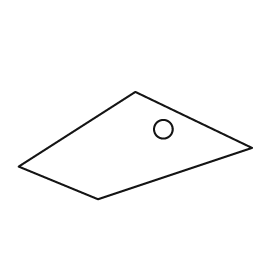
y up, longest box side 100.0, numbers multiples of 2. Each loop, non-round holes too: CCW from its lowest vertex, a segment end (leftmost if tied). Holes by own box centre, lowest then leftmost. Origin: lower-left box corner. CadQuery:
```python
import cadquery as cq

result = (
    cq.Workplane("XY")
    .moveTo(34.0, 0.0)
    .lineTo(100.0, 22.0)
    .lineTo(50.0, 46.0)
    .lineTo(0.0, 14.0)
    .close()
    .moveTo(62.0, 30.0)
    .circle(4.0)
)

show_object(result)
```